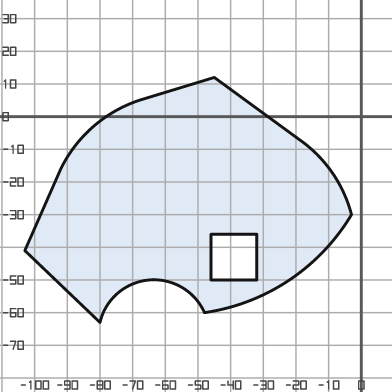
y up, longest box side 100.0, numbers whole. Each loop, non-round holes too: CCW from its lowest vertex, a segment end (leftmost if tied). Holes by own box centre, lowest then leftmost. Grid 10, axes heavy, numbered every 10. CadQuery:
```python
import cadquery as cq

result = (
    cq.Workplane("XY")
    .moveTo(-80.0, -63.0)
    .threePointArc((-65.0, -50.0), (-48.0, -60.0))
    .threePointArc((-22.0, -50.0), (-3.0, -30.0))
    .threePointArc((-9.0, -17.0), (-19.0, -7.0))
    .lineTo(-45.0, 12.0)
    .lineTo(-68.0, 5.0)
    .threePointArc((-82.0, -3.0), (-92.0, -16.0))
    .lineTo(-103.0, -41.0)
    .close()
    .moveTo(-46.0, -50.0)
    .lineTo(-32.0, -50.0)
    .lineTo(-32.0, -36.0)
    .lineTo(-46.0, -36.0)
    .close()
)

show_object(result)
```